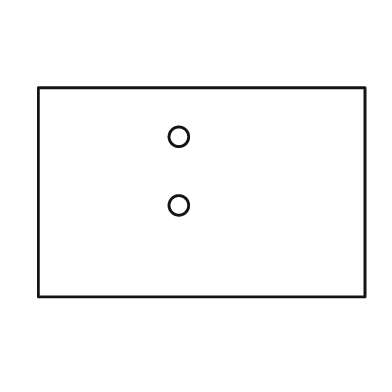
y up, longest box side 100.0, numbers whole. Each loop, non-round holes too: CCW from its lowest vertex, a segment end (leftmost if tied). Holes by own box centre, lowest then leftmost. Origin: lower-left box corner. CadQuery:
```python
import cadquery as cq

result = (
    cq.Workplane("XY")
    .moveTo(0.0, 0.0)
    .lineTo(100.0, 0.0)
    .lineTo(100.0, 64.0)
    .lineTo(0.0, 64.0)
    .close()
    .moveTo(43.0, 28.0)
    .circle(3.0)
    .moveTo(43.0, 49.0)
    .circle(3.0)
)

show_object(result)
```